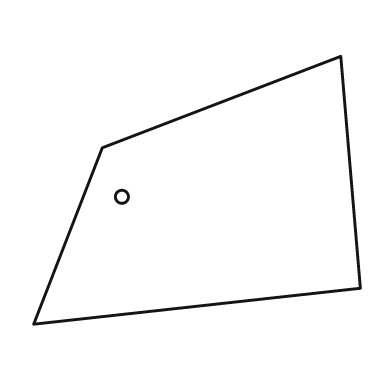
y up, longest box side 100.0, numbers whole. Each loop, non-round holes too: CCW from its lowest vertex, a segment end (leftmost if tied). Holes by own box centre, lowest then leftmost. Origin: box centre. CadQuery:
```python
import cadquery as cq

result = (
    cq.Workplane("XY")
    .moveTo(-50.0, -41.0)
    .lineTo(50.0, -30.0)
    .lineTo(44.0, 41.0)
    .lineTo(-29.0, 13.0)
    .close()
    .moveTo(-23.0, -2.0)
    .circle(2.0)
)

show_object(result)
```